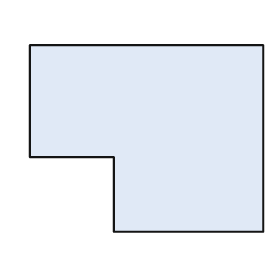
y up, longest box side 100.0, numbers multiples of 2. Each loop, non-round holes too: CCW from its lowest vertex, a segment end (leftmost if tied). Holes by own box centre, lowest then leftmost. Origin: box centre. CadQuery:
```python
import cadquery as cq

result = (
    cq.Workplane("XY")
    .moveTo(-14.0, -40.0)
    .lineTo(50.0, -40.0)
    .lineTo(50.0, 40.0)
    .lineTo(-50.0, 40.0)
    .lineTo(-50.0, -8.0)
    .lineTo(-14.0, -8.0)
    .close()
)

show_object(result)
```